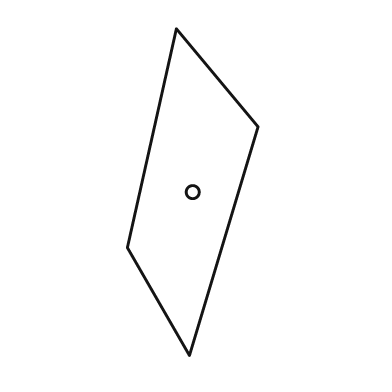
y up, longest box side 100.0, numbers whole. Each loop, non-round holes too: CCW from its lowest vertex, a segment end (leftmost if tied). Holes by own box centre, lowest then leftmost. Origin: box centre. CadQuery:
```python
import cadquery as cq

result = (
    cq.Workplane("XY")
    .moveTo(-1.0, -50.0)
    .lineTo(20.0, 20.0)
    .lineTo(-5.0, 50.0)
    .lineTo(-20.0, -17.0)
    .close()
    .moveTo(0.0, 0.0)
    .circle(2.0)
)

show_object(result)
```